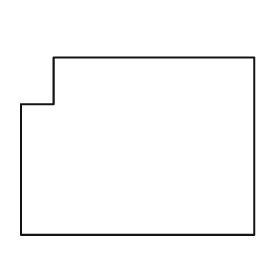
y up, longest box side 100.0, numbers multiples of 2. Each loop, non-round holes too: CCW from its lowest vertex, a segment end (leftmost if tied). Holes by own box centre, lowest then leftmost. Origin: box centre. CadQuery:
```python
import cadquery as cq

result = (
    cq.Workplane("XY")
    .moveTo(-50.0, -38.0)
    .lineTo(50.0, -38.0)
    .lineTo(50.0, 38.0)
    .lineTo(-36.0, 38.0)
    .lineTo(-36.0, 18.0)
    .lineTo(-50.0, 18.0)
    .close()
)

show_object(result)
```